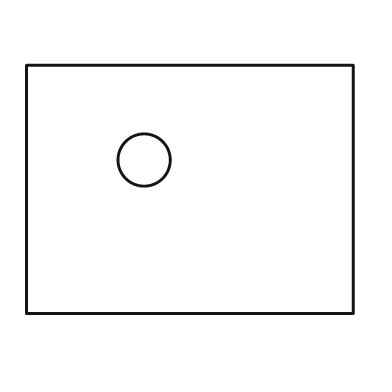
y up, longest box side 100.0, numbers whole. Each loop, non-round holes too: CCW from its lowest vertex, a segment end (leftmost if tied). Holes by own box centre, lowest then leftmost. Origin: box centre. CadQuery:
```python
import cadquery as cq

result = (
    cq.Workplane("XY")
    .moveTo(-50.0, -38.0)
    .lineTo(50.0, -38.0)
    .lineTo(50.0, 38.0)
    .lineTo(-50.0, 38.0)
    .close()
    .moveTo(-14.0, 9.0)
    .circle(8.0)
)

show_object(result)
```